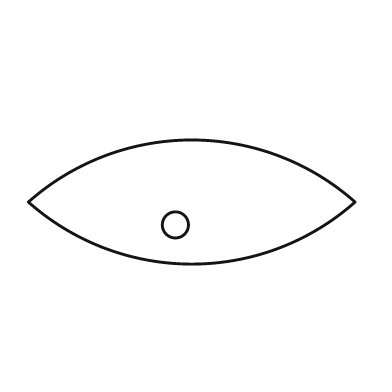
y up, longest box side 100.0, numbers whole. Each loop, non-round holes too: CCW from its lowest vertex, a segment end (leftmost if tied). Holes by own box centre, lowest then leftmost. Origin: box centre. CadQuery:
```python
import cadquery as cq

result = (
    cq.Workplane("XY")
    .moveTo(-50.0, 0.0)
    .threePointArc((0.0, -19.0), (50.0, 0.0))
    .threePointArc((0.0, 19.0), (-50.0, 0.0))
    .close()
    .moveTo(-5.0, -7.0)
    .circle(4.0)
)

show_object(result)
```